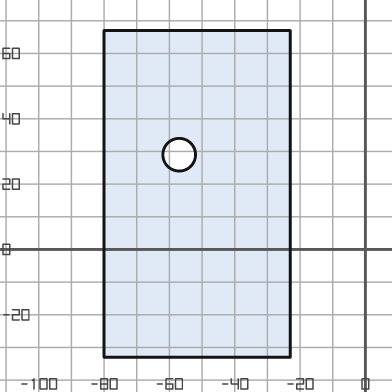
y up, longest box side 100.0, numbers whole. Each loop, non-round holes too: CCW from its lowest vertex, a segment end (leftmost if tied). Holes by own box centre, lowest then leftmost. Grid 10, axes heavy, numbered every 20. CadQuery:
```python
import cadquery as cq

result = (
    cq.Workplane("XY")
    .moveTo(-80.0, -33.0)
    .lineTo(-23.0, -33.0)
    .lineTo(-23.0, 67.0)
    .lineTo(-80.0, 67.0)
    .close()
    .moveTo(-57.0, 29.0)
    .circle(5.0)
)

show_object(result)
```